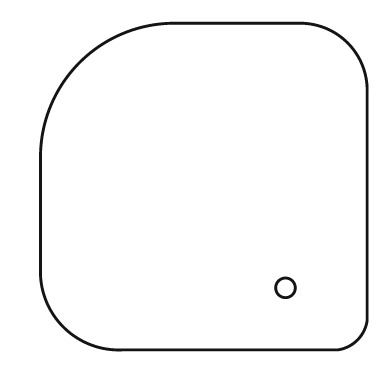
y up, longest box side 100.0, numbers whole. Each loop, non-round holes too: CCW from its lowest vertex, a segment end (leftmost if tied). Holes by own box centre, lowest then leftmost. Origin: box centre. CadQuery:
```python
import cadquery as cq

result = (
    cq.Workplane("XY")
    .moveTo(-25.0, -50.0)
    .lineTo(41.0, -50.0)
    .threePointArc((47.0, -47.0), (50.0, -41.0))
    .lineTo(50.0, 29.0)
    .threePointArc((44.0, 44.0), (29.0, 50.0))
    .lineTo(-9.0, 50.0)
    .threePointArc((-38.0, 38.0), (-50.0, 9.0))
    .lineTo(-50.0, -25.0)
    .threePointArc((-43.0, -43.0), (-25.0, -50.0))
    .close()
    .moveTo(25.0, -31.0)
    .circle(3.0)
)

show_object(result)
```